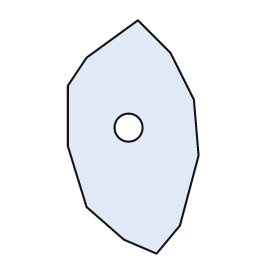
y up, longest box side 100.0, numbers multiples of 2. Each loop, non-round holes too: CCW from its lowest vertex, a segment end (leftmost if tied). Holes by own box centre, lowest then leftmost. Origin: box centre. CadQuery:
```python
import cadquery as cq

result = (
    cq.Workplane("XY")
    .moveTo(10.0, -50.0)
    .lineTo(20.0, -38.0)
    .lineTo(28.0, -8.0)
    .lineTo(26.0, 16.0)
    .lineTo(16.0, 36.0)
    .lineTo(2.0, 50.0)
    .lineTo(-20.0, 34.0)
    .lineTo(-28.0, 22.0)
    .lineTo(-28.0, -4.0)
    .lineTo(-20.0, -30.0)
    .lineTo(-4.0, -44.0)
    .close()
    .moveTo(-2.0, 4.0)
    .circle(6.0)
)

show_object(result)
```